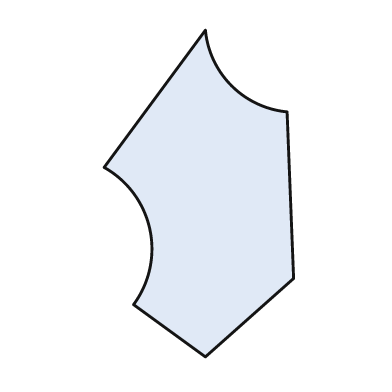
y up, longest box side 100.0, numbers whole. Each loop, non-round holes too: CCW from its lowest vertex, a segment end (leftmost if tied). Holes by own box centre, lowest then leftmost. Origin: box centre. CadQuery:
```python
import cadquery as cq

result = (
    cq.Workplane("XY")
    .moveTo(2.0, -50.0)
    .lineTo(29.0, -26.0)
    .lineTo(27.0, 25.0)
    .threePointArc((10.0, 33.0), (2.0, 50.0))
    .lineTo(-29.0, 8.0)
    .threePointArc((-15.0, -11.0), (-20.0, -34.0))
    .close()
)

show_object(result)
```